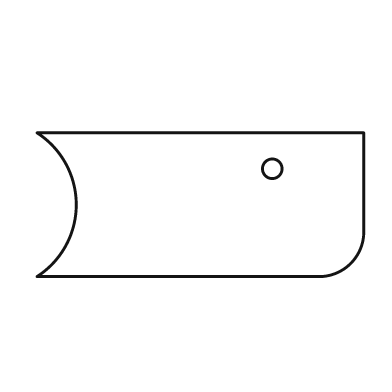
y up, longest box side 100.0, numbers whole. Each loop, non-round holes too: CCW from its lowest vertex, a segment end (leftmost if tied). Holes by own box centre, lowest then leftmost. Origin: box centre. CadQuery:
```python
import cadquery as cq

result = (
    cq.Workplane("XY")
    .moveTo(-50.0, -22.0)
    .lineTo(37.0, -22.0)
    .threePointArc((46.0, -18.0), (50.0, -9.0))
    .lineTo(50.0, 22.0)
    .lineTo(-50.0, 22.0)
    .threePointArc((-38.0, 0.0), (-50.0, -22.0))
    .close()
    .moveTo(22.0, 11.0)
    .circle(3.0)
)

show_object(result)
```